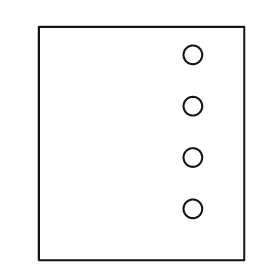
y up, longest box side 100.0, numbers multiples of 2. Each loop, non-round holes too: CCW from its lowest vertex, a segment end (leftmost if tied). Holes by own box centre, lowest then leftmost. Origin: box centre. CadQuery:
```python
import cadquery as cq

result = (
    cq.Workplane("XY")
    .moveTo(-44.0, -50.0)
    .lineTo(44.0, -50.0)
    .lineTo(44.0, 50.0)
    .lineTo(-44.0, 50.0)
    .close()
    .moveTo(22.0, -28.0)
    .circle(4.0)
    .moveTo(22.0, -6.0)
    .circle(4.0)
    .moveTo(22.0, 16.0)
    .circle(4.0)
    .moveTo(22.0, 38.0)
    .circle(4.0)
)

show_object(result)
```